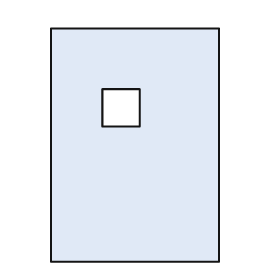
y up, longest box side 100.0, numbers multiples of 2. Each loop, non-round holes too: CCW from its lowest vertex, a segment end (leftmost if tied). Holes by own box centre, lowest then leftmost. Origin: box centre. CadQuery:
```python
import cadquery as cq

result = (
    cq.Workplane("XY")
    .moveTo(-36.0, -50.0)
    .lineTo(36.0, -50.0)
    .lineTo(36.0, 50.0)
    .lineTo(-36.0, 50.0)
    .close()
    .moveTo(-14.0, 8.0)
    .lineTo(2.0, 8.0)
    .lineTo(2.0, 24.0)
    .lineTo(-14.0, 24.0)
    .close()
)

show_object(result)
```